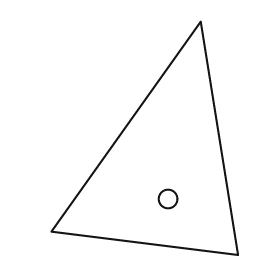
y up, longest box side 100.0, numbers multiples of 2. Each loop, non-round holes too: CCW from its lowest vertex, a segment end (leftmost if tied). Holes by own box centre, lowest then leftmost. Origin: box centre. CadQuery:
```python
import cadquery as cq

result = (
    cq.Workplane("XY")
    .moveTo(40.0, -50.0)
    .lineTo(24.0, 50.0)
    .lineTo(-40.0, -40.0)
    .close()
    .moveTo(10.0, -26.0)
    .circle(4.0)
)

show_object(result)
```